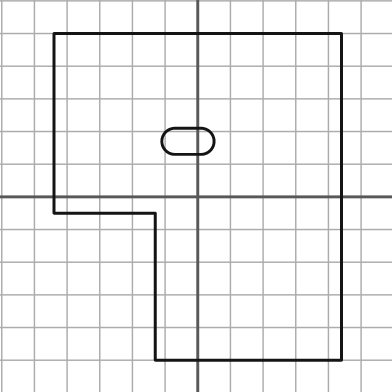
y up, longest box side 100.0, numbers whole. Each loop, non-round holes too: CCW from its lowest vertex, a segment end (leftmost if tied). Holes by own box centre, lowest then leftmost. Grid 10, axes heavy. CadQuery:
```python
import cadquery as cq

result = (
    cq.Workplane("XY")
    .moveTo(-13.0, -50.0)
    .lineTo(44.0, -50.0)
    .lineTo(44.0, 50.0)
    .lineTo(-44.0, 50.0)
    .lineTo(-44.0, -5.0)
    .lineTo(-13.0, -5.0)
    .close()
    .moveTo(-7.0, 13.0)
    .lineTo(1.0, 13.0)
    .threePointArc((5.0, 17.0), (1.0, 21.0))
    .lineTo(-7.0, 21.0)
    .threePointArc((-11.0, 17.0), (-7.0, 13.0))
    .close()
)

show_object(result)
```